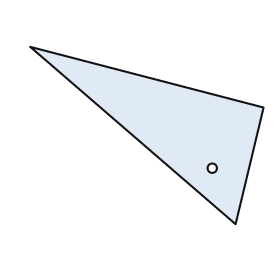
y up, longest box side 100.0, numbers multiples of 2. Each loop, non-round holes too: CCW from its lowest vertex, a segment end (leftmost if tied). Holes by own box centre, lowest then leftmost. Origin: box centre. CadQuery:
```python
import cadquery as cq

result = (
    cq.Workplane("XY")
    .moveTo(38.0, -38.0)
    .lineTo(50.0, 12.0)
    .lineTo(-50.0, 38.0)
    .close()
    .moveTo(28.0, -14.0)
    .circle(2.0)
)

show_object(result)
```